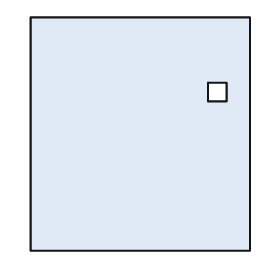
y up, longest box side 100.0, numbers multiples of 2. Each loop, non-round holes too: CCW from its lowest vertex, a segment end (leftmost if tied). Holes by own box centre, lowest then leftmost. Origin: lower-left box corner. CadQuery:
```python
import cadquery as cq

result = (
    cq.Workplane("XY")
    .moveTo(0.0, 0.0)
    .lineTo(94.0, 0.0)
    .lineTo(94.0, 100.0)
    .lineTo(0.0, 100.0)
    .close()
    .moveTo(76.0, 64.0)
    .lineTo(84.0, 64.0)
    .lineTo(84.0, 72.0)
    .lineTo(76.0, 72.0)
    .close()
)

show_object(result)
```